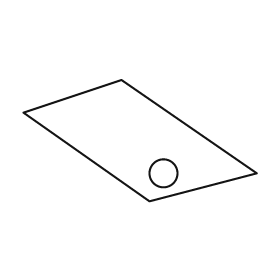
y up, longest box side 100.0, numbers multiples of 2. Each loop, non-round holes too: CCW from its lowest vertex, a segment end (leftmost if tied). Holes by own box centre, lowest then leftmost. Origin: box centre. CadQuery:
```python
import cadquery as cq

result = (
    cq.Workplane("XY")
    .moveTo(4.0, -26.0)
    .lineTo(50.0, -14.0)
    .lineTo(-8.0, 26.0)
    .lineTo(-50.0, 12.0)
    .close()
    .moveTo(10.0, -14.0)
    .circle(6.0)
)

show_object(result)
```